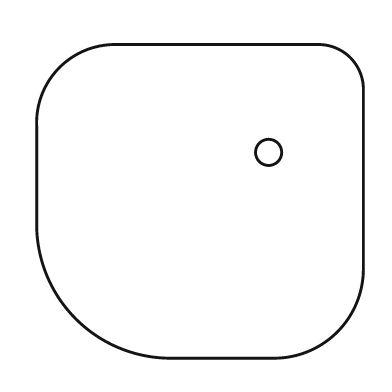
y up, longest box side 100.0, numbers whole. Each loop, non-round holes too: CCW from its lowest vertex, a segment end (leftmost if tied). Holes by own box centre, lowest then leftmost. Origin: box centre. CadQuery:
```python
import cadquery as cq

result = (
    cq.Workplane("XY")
    .moveTo(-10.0, -48.0)
    .lineTo(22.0, -48.0)
    .threePointArc((42.0, -40.0), (50.0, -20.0))
    .lineTo(50.0, 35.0)
    .threePointArc((46.0, 44.0), (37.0, 48.0))
    .lineTo(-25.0, 48.0)
    .threePointArc((-43.0, 41.0), (-50.0, 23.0))
    .lineTo(-50.0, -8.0)
    .threePointArc((-38.0, -36.0), (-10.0, -48.0))
    .close()
    .moveTo(21.0, 15.0)
    .circle(4.0)
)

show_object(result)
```